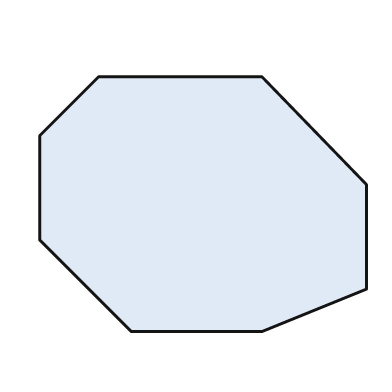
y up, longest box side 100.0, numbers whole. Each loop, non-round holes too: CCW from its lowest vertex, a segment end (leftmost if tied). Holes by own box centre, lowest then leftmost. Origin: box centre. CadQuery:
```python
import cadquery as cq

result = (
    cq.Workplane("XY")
    .moveTo(-22.0, -39.0)
    .lineTo(18.0, -39.0)
    .lineTo(50.0, -26.0)
    .lineTo(50.0, 6.0)
    .lineTo(18.0, 39.0)
    .lineTo(-32.0, 39.0)
    .lineTo(-50.0, 21.0)
    .lineTo(-50.0, -11.0)
    .close()
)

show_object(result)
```